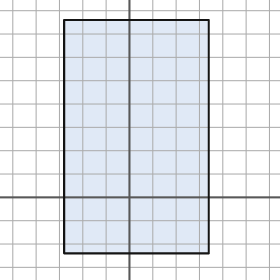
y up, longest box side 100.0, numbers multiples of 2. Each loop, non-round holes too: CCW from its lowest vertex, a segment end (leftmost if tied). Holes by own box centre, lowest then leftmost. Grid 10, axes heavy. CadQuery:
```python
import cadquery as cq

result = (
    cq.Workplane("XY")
    .moveTo(-28.0, -24.0)
    .lineTo(34.0, -24.0)
    .lineTo(34.0, 76.0)
    .lineTo(-28.0, 76.0)
    .close()
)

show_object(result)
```